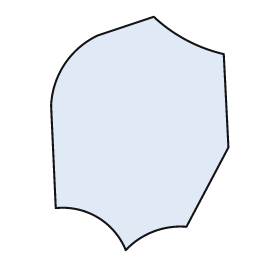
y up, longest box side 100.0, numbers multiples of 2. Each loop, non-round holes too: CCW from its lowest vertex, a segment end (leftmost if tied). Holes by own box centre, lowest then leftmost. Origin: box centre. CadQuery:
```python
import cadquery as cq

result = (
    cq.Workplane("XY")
    .moveTo(-6.0, -50.0)
    .threePointArc((6.0, -42.0), (20.0, -40.0))
    .lineTo(38.0, -6.0)
    .lineTo(36.0, 34.0)
    .threePointArc((20.0, 40.0), (6.0, 50.0))
    .lineTo(-18.0, 42.0)
    .threePointArc((-32.0, 30.0), (-38.0, 12.0))
    .lineTo(-36.0, -32.0)
    .threePointArc((-18.0, -36.0), (-6.0, -50.0))
    .close()
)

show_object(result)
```